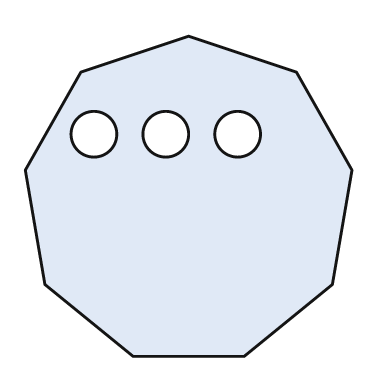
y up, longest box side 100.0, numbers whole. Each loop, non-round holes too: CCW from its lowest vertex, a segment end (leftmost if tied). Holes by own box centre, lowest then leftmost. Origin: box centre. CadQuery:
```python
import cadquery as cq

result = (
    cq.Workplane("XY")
    .moveTo(-17.0, -49.0)
    .lineTo(17.0, -49.0)
    .lineTo(44.0, -27.0)
    .lineTo(50.0, 8.0)
    .lineTo(33.0, 38.0)
    .lineTo(0.0, 49.0)
    .lineTo(-33.0, 38.0)
    .lineTo(-50.0, 8.0)
    .lineTo(-44.0, -27.0)
    .close()
    .moveTo(-29.0, 19.0)
    .circle(7.0)
    .moveTo(-7.0, 19.0)
    .circle(7.0)
    .moveTo(15.0, 19.0)
    .circle(7.0)
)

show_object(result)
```